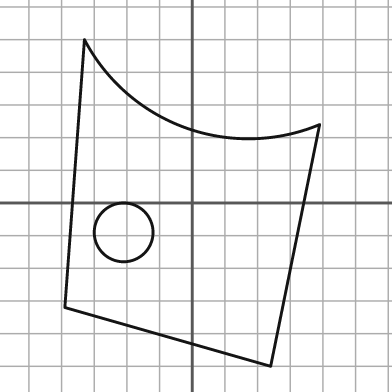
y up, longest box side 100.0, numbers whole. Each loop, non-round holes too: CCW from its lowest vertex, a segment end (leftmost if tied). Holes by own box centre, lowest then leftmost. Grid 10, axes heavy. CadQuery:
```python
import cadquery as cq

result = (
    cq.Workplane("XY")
    .moveTo(24.0, -50.0)
    .lineTo(39.0, 24.0)
    .threePointArc((-2.0, 23.0), (-33.0, 50.0))
    .lineTo(-39.0, -32.0)
    .close()
    .moveTo(-21.0, -9.0)
    .circle(9.0)
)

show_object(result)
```